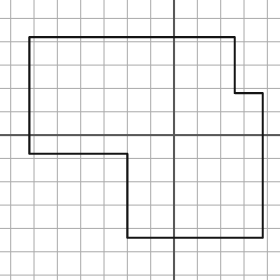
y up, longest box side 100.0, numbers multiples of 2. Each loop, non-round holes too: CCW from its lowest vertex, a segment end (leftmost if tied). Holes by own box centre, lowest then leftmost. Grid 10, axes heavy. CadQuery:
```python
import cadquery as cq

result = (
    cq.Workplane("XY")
    .moveTo(-20.0, -44.0)
    .lineTo(38.0, -44.0)
    .lineTo(38.0, 18.0)
    .lineTo(26.0, 18.0)
    .lineTo(26.0, 42.0)
    .lineTo(-62.0, 42.0)
    .lineTo(-62.0, -8.0)
    .lineTo(-20.0, -8.0)
    .close()
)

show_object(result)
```